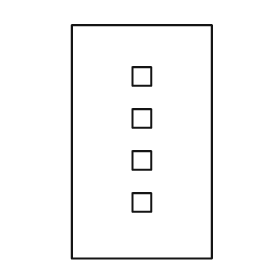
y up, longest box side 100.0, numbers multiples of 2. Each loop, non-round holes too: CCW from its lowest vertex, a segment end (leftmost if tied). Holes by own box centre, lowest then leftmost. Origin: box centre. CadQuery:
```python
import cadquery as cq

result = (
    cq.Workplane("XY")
    .moveTo(-30.0, -50.0)
    .lineTo(30.0, -50.0)
    .lineTo(30.0, 50.0)
    .lineTo(-30.0, 50.0)
    .close()
    .moveTo(-4.0, -30.0)
    .lineTo(4.0, -30.0)
    .lineTo(4.0, -22.0)
    .lineTo(-4.0, -22.0)
    .close()
    .moveTo(-4.0, -12.0)
    .lineTo(4.0, -12.0)
    .lineTo(4.0, -4.0)
    .lineTo(-4.0, -4.0)
    .close()
    .moveTo(-4.0, 6.0)
    .lineTo(4.0, 6.0)
    .lineTo(4.0, 14.0)
    .lineTo(-4.0, 14.0)
    .close()
    .moveTo(-4.0, 24.0)
    .lineTo(4.0, 24.0)
    .lineTo(4.0, 32.0)
    .lineTo(-4.0, 32.0)
    .close()
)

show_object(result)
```